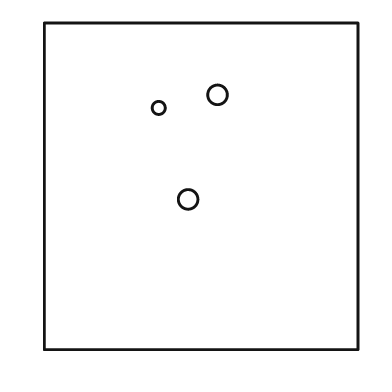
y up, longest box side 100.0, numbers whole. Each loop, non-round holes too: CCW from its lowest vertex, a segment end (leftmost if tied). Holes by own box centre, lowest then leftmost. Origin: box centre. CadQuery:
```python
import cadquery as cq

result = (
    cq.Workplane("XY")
    .moveTo(-48.0, -50.0)
    .lineTo(48.0, -50.0)
    .lineTo(48.0, 50.0)
    .lineTo(-48.0, 50.0)
    .close()
    .moveTo(-4.0, -4.0)
    .circle(3.0)
    .moveTo(-13.0, 24.0)
    .circle(2.0)
    .moveTo(5.0, 28.0)
    .circle(3.0)
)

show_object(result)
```